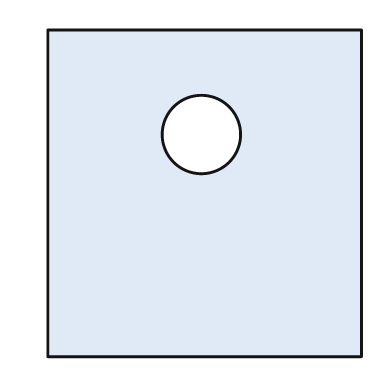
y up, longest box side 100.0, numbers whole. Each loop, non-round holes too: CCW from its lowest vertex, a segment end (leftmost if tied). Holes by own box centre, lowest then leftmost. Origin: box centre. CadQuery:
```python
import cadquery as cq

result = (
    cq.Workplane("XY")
    .moveTo(-48.0, -50.0)
    .lineTo(48.0, -50.0)
    .lineTo(48.0, 50.0)
    .lineTo(-48.0, 50.0)
    .close()
    .moveTo(-1.0, 18.0)
    .circle(12.0)
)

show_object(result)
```